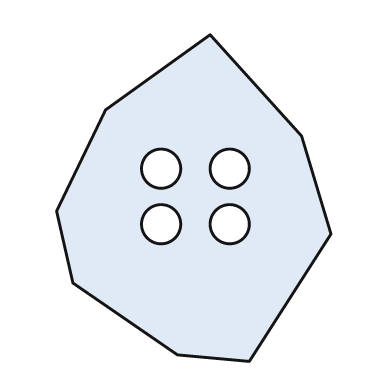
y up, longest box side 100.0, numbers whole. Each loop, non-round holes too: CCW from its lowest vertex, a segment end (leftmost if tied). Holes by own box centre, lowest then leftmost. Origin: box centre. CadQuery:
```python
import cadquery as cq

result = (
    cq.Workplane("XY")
    .moveTo(17.0, -50.0)
    .lineTo(42.0, -11.0)
    .lineTo(33.0, 19.0)
    .lineTo(5.0, 50.0)
    .lineTo(-27.0, 27.0)
    .lineTo(-42.0, -4.0)
    .lineTo(-37.0, -26.0)
    .lineTo(-5.0, -48.0)
    .close()
    .moveTo(-10.0, -8.0)
    .circle(6.0)
    .moveTo(11.0, -8.0)
    .circle(6.0)
    .moveTo(-10.0, 9.0)
    .circle(6.0)
    .moveTo(11.0, 9.0)
    .circle(6.0)
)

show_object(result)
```